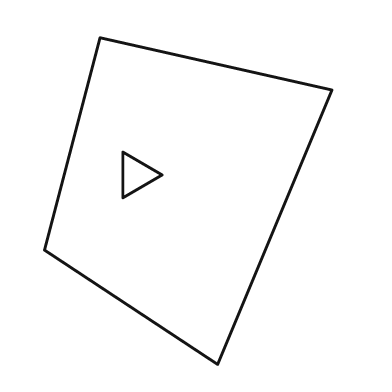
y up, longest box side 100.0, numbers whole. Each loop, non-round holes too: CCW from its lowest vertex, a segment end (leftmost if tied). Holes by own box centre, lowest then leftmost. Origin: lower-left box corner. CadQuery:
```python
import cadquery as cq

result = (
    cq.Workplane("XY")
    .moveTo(53.0, 0.0)
    .lineTo(88.0, 84.0)
    .lineTo(17.0, 100.0)
    .lineTo(0.0, 35.0)
    .close()
    .moveTo(24.0, 51.0)
    .lineTo(36.0, 58.0)
    .lineTo(24.0, 65.0)
    .close()
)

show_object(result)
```